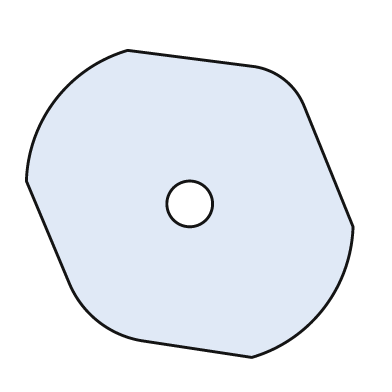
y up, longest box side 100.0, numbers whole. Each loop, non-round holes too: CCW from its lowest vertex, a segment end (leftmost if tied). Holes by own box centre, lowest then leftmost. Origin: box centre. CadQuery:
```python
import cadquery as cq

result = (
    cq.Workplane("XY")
    .moveTo(19.0, -47.0)
    .threePointArc((41.0, -32.0), (50.0, -7.0))
    .lineTo(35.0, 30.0)
    .threePointArc((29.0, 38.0), (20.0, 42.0))
    .lineTo(-19.0, 47.0)
    .threePointArc((-41.0, 32.0), (-50.0, 7.0))
    .lineTo(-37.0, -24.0)
    .threePointArc((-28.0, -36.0), (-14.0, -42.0))
    .close()
    .moveTo(0.0, 0.0)
    .circle(7.0)
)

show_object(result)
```